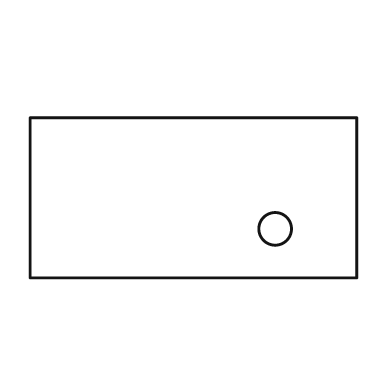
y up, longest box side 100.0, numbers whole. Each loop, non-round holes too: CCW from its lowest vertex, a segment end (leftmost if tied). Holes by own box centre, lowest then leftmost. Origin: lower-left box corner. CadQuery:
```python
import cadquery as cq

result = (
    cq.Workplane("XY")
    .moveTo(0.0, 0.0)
    .lineTo(100.0, 0.0)
    .lineTo(100.0, 49.0)
    .lineTo(0.0, 49.0)
    .close()
    .moveTo(75.0, 15.0)
    .circle(5.0)
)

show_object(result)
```